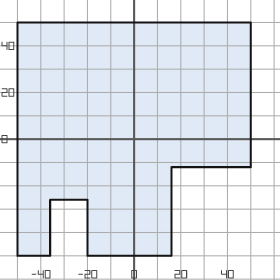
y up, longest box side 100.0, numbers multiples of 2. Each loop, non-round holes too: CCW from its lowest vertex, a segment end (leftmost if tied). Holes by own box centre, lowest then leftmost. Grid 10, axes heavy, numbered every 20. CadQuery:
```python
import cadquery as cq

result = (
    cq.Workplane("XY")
    .moveTo(-50.0, -50.0)
    .lineTo(-36.0, -50.0)
    .lineTo(-36.0, -26.0)
    .lineTo(-20.0, -26.0)
    .lineTo(-20.0, -50.0)
    .lineTo(16.0, -50.0)
    .lineTo(16.0, -12.0)
    .lineTo(50.0, -12.0)
    .lineTo(50.0, 50.0)
    .lineTo(-50.0, 50.0)
    .close()
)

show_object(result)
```